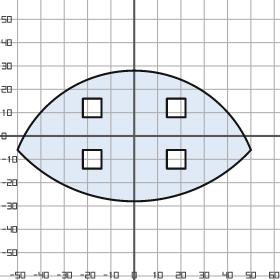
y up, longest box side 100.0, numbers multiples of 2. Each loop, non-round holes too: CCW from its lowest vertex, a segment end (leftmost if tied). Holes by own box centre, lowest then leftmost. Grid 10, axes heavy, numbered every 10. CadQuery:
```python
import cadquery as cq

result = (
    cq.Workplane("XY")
    .moveTo(-50.0, -6.0)
    .threePointArc((0.0, -28.0), (50.0, -6.0))
    .threePointArc((0.0, 28.0), (-50.0, -6.0))
    .close()
    .moveTo(-22.0, -14.0)
    .lineTo(-14.0, -14.0)
    .lineTo(-14.0, -6.0)
    .lineTo(-22.0, -6.0)
    .close()
    .moveTo(14.0, -14.0)
    .lineTo(22.0, -14.0)
    .lineTo(22.0, -6.0)
    .lineTo(14.0, -6.0)
    .close()
    .moveTo(-22.0, 8.0)
    .lineTo(-14.0, 8.0)
    .lineTo(-14.0, 16.0)
    .lineTo(-22.0, 16.0)
    .close()
    .moveTo(14.0, 8.0)
    .lineTo(22.0, 8.0)
    .lineTo(22.0, 16.0)
    .lineTo(14.0, 16.0)
    .close()
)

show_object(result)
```